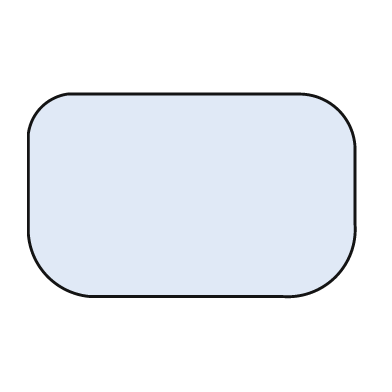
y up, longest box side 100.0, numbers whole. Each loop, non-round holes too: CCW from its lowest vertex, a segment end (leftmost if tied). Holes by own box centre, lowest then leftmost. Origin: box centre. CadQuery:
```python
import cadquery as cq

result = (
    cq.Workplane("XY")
    .moveTo(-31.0, -31.0)
    .lineTo(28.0, -31.0)
    .threePointArc((44.0, -25.0), (50.0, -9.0))
    .lineTo(50.0, 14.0)
    .threePointArc((45.0, 26.0), (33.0, 31.0))
    .lineTo(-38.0, 31.0)
    .threePointArc((-46.0, 27.0), (-50.0, 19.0))
    .lineTo(-50.0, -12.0)
    .threePointArc((-44.0, -25.0), (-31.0, -31.0))
    .close()
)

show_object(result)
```